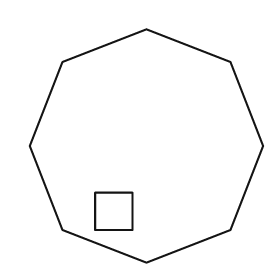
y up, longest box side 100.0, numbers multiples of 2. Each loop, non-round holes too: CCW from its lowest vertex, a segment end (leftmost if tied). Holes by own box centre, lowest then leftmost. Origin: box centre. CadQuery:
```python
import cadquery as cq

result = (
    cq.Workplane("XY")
    .moveTo(0.0, -50.0)
    .lineTo(36.0, -36.0)
    .lineTo(50.0, 0.0)
    .lineTo(36.0, 36.0)
    .lineTo(0.0, 50.0)
    .lineTo(-36.0, 36.0)
    .lineTo(-50.0, 0.0)
    .lineTo(-36.0, -36.0)
    .close()
    .moveTo(-22.0, -36.0)
    .lineTo(-6.0, -36.0)
    .lineTo(-6.0, -20.0)
    .lineTo(-22.0, -20.0)
    .close()
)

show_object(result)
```